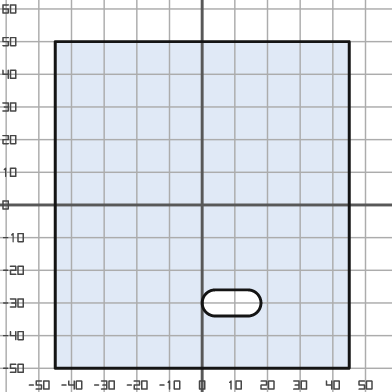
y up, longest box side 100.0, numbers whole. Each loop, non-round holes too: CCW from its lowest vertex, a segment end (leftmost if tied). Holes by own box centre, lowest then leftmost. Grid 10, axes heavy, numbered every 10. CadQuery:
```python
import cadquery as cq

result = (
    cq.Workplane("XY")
    .moveTo(-45.0, -50.0)
    .lineTo(45.0, -50.0)
    .lineTo(45.0, 50.0)
    .lineTo(-45.0, 50.0)
    .close()
    .moveTo(4.0, -34.0)
    .lineTo(14.0, -34.0)
    .threePointArc((18.0, -30.0), (14.0, -26.0))
    .lineTo(4.0, -26.0)
    .threePointArc((0.0, -30.0), (4.0, -34.0))
    .close()
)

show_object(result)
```